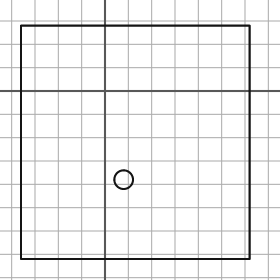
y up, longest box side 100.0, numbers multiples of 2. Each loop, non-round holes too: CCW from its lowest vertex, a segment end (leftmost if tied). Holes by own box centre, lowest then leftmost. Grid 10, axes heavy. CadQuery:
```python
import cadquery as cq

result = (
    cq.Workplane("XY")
    .moveTo(-36.0, -72.0)
    .lineTo(62.0, -72.0)
    .lineTo(62.0, 28.0)
    .lineTo(-36.0, 28.0)
    .close()
    .moveTo(8.0, -38.0)
    .circle(4.0)
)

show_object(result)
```